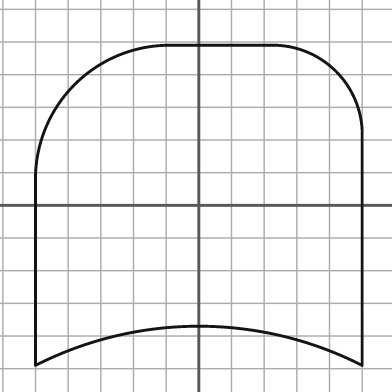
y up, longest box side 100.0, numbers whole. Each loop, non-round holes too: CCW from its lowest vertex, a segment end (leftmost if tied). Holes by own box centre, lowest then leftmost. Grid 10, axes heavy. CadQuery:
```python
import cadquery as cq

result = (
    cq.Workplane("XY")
    .moveTo(-50.0, -49.0)
    .threePointArc((0.0, -37.0), (50.0, -49.0))
    .lineTo(50.0, 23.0)
    .threePointArc((42.0, 41.0), (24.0, 49.0))
    .lineTo(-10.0, 49.0)
    .threePointArc((-38.0, 37.0), (-50.0, 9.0))
    .close()
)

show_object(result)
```